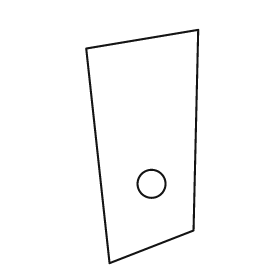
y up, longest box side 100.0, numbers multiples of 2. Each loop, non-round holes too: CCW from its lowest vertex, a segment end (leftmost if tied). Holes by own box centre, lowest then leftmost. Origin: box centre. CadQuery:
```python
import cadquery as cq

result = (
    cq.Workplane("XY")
    .moveTo(-14.0, -50.0)
    .lineTo(22.0, -36.0)
    .lineTo(24.0, 50.0)
    .lineTo(-24.0, 42.0)
    .close()
    .moveTo(4.0, -16.0)
    .circle(6.0)
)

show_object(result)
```